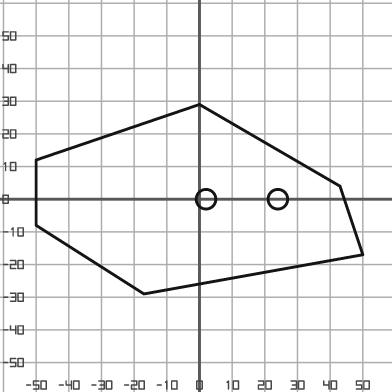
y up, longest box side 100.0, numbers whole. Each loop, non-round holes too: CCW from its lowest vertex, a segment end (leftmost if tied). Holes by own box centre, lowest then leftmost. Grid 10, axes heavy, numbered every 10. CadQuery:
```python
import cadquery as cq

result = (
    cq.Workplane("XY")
    .moveTo(-17.0, -29.0)
    .lineTo(50.0, -17.0)
    .lineTo(43.0, 4.0)
    .lineTo(0.0, 29.0)
    .lineTo(-50.0, 12.0)
    .lineTo(-50.0, -8.0)
    .close()
    .moveTo(2.0, 0.0)
    .circle(3.0)
    .moveTo(24.0, 0.0)
    .circle(3.0)
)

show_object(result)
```